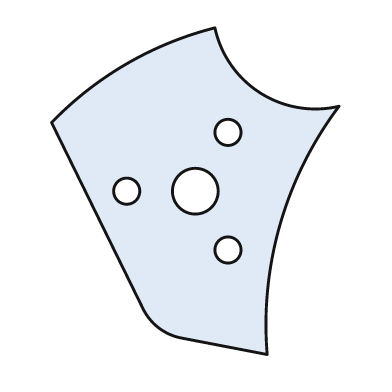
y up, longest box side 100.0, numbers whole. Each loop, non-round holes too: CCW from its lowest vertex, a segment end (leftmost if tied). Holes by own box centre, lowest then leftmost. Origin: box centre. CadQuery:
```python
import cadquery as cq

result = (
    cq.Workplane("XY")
    .moveTo(22.0, -50.0)
    .threePointArc((26.0, -10.0), (44.0, 26.0))
    .threePointArc((20.0, 30.0), (6.0, 50.0))
    .threePointArc((-21.0, 39.0), (-44.0, 21.0))
    .lineTo(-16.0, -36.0)
    .threePointArc((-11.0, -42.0), (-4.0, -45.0))
    .close()
    .moveTo(10.0, -18.0)
    .circle(4.0)
    .moveTo(-21.0, 0.0)
    .circle(4.0)
    .moveTo(0.0, 0.0)
    .circle(7.0)
    .moveTo(10.0, 18.0)
    .circle(4.0)
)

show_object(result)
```